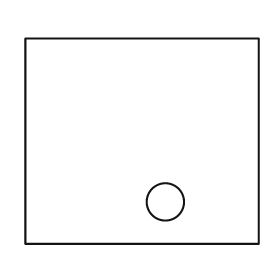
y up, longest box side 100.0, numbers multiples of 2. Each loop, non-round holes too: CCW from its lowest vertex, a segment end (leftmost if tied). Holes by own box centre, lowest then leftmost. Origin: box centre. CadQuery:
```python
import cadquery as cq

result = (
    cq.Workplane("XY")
    .moveTo(-50.0, -44.0)
    .lineTo(50.0, -44.0)
    .lineTo(50.0, 44.0)
    .lineTo(-50.0, 44.0)
    .close()
    .moveTo(10.0, -26.0)
    .circle(8.0)
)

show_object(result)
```